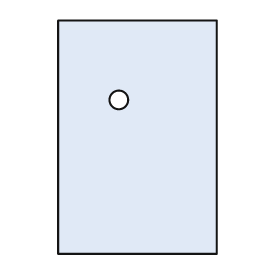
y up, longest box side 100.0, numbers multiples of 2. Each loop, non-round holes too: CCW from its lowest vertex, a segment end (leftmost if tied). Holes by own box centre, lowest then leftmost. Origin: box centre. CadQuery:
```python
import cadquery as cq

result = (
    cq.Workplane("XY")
    .moveTo(-34.0, -50.0)
    .lineTo(34.0, -50.0)
    .lineTo(34.0, 50.0)
    .lineTo(-34.0, 50.0)
    .close()
    .moveTo(-8.0, 16.0)
    .circle(4.0)
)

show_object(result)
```